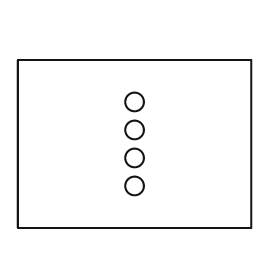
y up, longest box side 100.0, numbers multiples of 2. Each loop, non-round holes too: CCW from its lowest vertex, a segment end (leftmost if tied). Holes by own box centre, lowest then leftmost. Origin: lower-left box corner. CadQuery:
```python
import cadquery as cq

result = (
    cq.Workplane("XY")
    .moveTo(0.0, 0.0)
    .lineTo(100.0, 0.0)
    .lineTo(100.0, 72.0)
    .lineTo(0.0, 72.0)
    .close()
    .moveTo(50.0, 18.0)
    .circle(4.0)
    .moveTo(50.0, 30.0)
    .circle(4.0)
    .moveTo(50.0, 42.0)
    .circle(4.0)
    .moveTo(50.0, 54.0)
    .circle(4.0)
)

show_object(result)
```